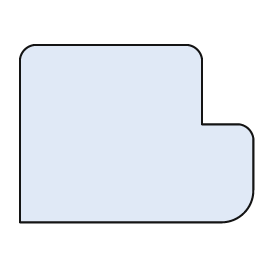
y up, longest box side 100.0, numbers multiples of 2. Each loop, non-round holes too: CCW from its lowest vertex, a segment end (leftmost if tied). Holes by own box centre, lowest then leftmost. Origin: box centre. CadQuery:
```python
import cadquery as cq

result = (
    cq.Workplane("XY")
    .moveTo(-50.0, -38.0)
    .lineTo(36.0, -38.0)
    .threePointArc((46.0, -34.0), (50.0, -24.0))
    .lineTo(50.0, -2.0)
    .threePointArc((48.0, 2.0), (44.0, 4.0))
    .lineTo(28.0, 4.0)
    .lineTo(28.0, 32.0)
    .threePointArc((26.0, 36.0), (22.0, 38.0))
    .lineTo(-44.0, 38.0)
    .threePointArc((-48.0, 36.0), (-50.0, 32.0))
    .close()
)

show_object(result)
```